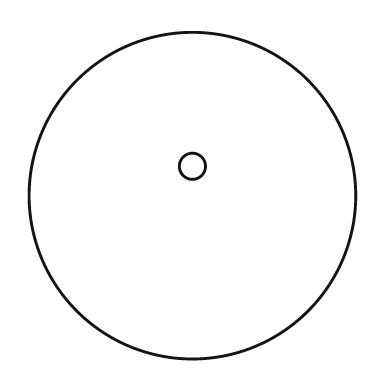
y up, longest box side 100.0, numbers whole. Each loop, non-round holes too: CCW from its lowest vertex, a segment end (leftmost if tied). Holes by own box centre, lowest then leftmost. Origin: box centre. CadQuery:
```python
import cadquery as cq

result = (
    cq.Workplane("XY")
    .moveTo(0.0, 0.0)
    .circle(50.0)
    .moveTo(0.0, 9.0)
    .circle(4.0)
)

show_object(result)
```